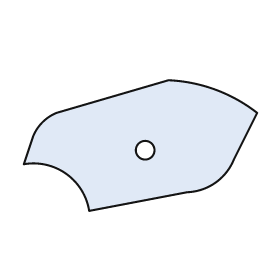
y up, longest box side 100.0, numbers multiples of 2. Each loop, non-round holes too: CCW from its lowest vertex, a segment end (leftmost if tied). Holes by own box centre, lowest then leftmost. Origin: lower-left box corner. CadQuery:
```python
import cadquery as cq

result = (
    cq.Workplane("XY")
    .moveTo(28.0, 0.0)
    .lineTo(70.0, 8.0)
    .threePointArc((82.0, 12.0), (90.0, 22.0))
    .lineTo(100.0, 42.0)
    .threePointArc((82.0, 52.0), (62.0, 56.0))
    .lineTo(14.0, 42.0)
    .threePointArc((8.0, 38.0), (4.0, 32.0))
    .lineTo(0.0, 20.0)
    .threePointArc((18.0, 16.0), (28.0, 0.0))
    .close()
    .moveTo(52.0, 26.0)
    .circle(4.0)
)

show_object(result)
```